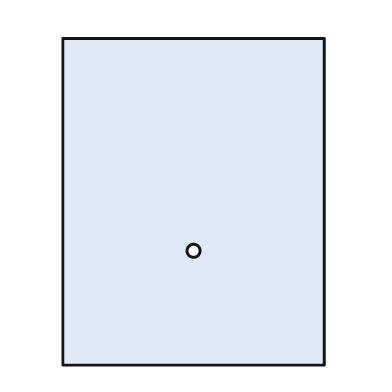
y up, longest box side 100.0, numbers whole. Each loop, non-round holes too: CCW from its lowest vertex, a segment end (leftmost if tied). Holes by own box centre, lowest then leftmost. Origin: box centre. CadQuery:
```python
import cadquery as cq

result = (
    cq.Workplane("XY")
    .moveTo(-40.0, -50.0)
    .lineTo(40.0, -50.0)
    .lineTo(40.0, 50.0)
    .lineTo(-40.0, 50.0)
    .close()
    .moveTo(0.0, -15.0)
    .circle(2.0)
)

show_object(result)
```